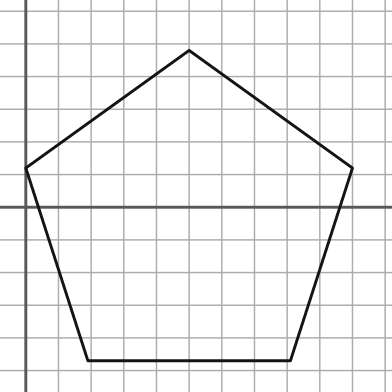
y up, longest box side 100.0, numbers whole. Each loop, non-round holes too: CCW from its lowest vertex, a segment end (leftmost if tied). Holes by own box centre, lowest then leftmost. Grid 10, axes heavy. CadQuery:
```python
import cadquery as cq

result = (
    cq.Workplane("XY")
    .moveTo(19.0, -47.0)
    .lineTo(81.0, -47.0)
    .lineTo(100.0, 12.0)
    .lineTo(50.0, 48.0)
    .lineTo(0.0, 12.0)
    .close()
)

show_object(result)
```